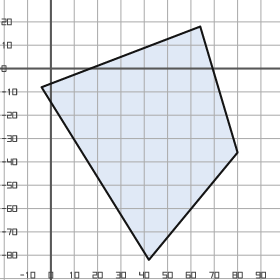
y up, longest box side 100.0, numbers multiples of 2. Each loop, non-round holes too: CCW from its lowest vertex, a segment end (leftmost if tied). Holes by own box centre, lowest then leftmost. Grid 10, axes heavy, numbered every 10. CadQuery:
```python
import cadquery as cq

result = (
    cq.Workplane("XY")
    .moveTo(42.0, -82.0)
    .lineTo(80.0, -36.0)
    .lineTo(64.0, 18.0)
    .lineTo(-4.0, -8.0)
    .close()
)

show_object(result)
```